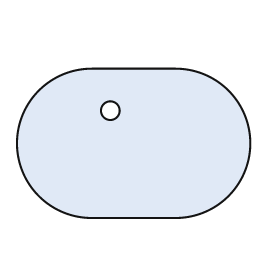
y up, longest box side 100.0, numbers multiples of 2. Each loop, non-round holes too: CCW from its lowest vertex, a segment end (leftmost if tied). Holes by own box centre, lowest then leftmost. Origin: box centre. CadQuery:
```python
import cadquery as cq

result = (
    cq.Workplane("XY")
    .moveTo(-18.0, -32.0)
    .lineTo(18.0, -32.0)
    .threePointArc((50.0, 0.0), (18.0, 32.0))
    .lineTo(-18.0, 32.0)
    .threePointArc((-50.0, 0.0), (-18.0, -32.0))
    .close()
    .moveTo(-10.0, 14.0)
    .circle(4.0)
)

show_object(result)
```